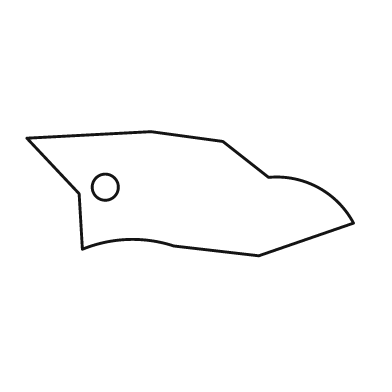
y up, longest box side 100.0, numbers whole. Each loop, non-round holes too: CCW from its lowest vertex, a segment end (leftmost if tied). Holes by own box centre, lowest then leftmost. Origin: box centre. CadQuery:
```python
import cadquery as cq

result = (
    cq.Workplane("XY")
    .moveTo(21.0, -19.0)
    .lineTo(50.0, -9.0)
    .threePointArc((39.0, 2.0), (24.0, 5.0))
    .lineTo(10.0, 16.0)
    .lineTo(-12.0, 19.0)
    .lineTo(-50.0, 17.0)
    .lineTo(-34.0, 0.0)
    .lineTo(-33.0, -17.0)
    .threePointArc((-19.0, -14.0), (-5.0, -16.0))
    .close()
    .moveTo(-26.0, 2.0)
    .circle(4.0)
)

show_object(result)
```